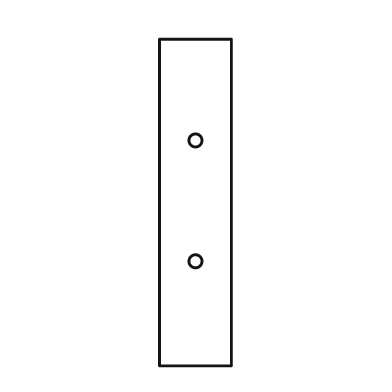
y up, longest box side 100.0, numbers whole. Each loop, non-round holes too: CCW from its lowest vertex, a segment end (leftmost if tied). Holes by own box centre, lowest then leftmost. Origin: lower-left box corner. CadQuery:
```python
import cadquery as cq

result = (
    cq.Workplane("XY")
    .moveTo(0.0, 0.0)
    .lineTo(22.0, 0.0)
    .lineTo(22.0, 100.0)
    .lineTo(0.0, 100.0)
    .close()
    .moveTo(11.0, 32.0)
    .circle(2.0)
    .moveTo(11.0, 69.0)
    .circle(2.0)
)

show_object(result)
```